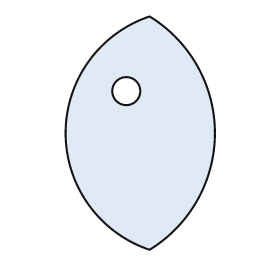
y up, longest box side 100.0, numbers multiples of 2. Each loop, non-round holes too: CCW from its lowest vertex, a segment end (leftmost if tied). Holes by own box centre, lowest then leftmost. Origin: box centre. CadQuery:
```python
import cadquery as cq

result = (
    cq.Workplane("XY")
    .moveTo(4.0, -50.0)
    .threePointArc((32.0, 0.0), (4.0, 50.0))
    .threePointArc((-32.0, 0.0), (4.0, -50.0))
    .close()
    .moveTo(-6.0, 18.0)
    .circle(6.0)
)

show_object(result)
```